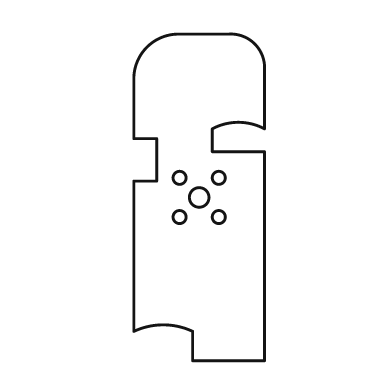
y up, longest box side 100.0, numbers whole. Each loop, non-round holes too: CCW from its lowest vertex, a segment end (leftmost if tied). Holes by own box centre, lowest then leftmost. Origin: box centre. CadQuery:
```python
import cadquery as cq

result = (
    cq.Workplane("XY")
    .moveTo(-2.0, -50.0)
    .lineTo(20.0, -50.0)
    .lineTo(20.0, 14.0)
    .lineTo(4.0, 14.0)
    .lineTo(4.0, 21.0)
    .threePointArc((12.0, 23.0), (20.0, 21.0))
    .lineTo(20.0, 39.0)
    .threePointArc((17.0, 47.0), (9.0, 50.0))
    .lineTo(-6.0, 50.0)
    .threePointArc((-16.0, 46.0), (-20.0, 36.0))
    .lineTo(-20.0, 18.0)
    .lineTo(-13.0, 18.0)
    .lineTo(-13.0, 5.0)
    .lineTo(-20.0, 5.0)
    .lineTo(-20.0, -41.0)
    .threePointArc((-11.0, -39.0), (-2.0, -41.0))
    .close()
    .moveTo(-6.0, -6.0)
    .circle(2.0)
    .moveTo(6.0, -6.0)
    .circle(2.0)
    .moveTo(0.0, 0.0)
    .circle(3.0)
    .moveTo(-6.0, 6.0)
    .circle(2.0)
    .moveTo(6.0, 6.0)
    .circle(2.0)
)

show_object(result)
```